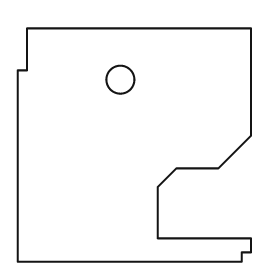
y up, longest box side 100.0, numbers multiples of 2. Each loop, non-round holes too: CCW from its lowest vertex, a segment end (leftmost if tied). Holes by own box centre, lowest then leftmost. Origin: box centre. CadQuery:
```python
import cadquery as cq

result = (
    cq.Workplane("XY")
    .moveTo(-50.0, -50.0)
    .lineTo(46.0, -50.0)
    .lineTo(46.0, -46.0)
    .lineTo(50.0, -46.0)
    .lineTo(50.0, -40.0)
    .lineTo(10.0, -40.0)
    .lineTo(10.0, -18.0)
    .lineTo(18.0, -10.0)
    .lineTo(36.0, -10.0)
    .lineTo(50.0, 4.0)
    .lineTo(50.0, 50.0)
    .lineTo(-46.0, 50.0)
    .lineTo(-46.0, 32.0)
    .lineTo(-50.0, 32.0)
    .close()
    .moveTo(-6.0, 28.0)
    .circle(6.0)
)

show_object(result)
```